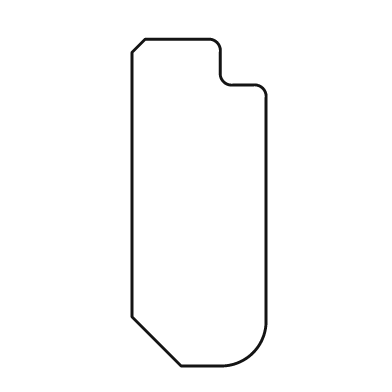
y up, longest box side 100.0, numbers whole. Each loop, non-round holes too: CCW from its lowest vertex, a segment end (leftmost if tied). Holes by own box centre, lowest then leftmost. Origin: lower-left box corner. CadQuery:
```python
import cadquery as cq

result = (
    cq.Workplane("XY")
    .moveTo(15.0, 0.0)
    .lineTo(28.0, 0.0)
    .threePointArc((37.0, 4.0), (41.0, 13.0))
    .lineTo(41.0, 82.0)
    .threePointArc((40.0, 85.0), (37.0, 86.0))
    .lineTo(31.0, 86.0)
    .threePointArc((28.0, 87.0), (27.0, 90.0))
    .lineTo(27.0, 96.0)
    .threePointArc((26.0, 99.0), (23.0, 100.0))
    .lineTo(4.0, 100.0)
    .lineTo(0.0, 96.0)
    .lineTo(0.0, 15.0)
    .close()
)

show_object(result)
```